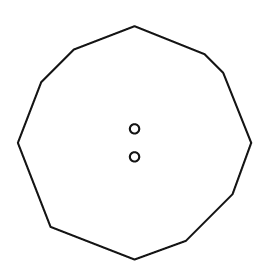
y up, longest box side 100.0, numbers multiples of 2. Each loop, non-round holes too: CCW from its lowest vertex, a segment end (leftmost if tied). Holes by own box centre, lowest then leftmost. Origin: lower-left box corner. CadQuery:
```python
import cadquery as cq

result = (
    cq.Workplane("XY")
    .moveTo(50.0, 0.0)
    .lineTo(72.0, 8.0)
    .lineTo(92.0, 28.0)
    .lineTo(100.0, 50.0)
    .lineTo(88.0, 80.0)
    .lineTo(80.0, 88.0)
    .lineTo(50.0, 100.0)
    .lineTo(24.0, 90.0)
    .lineTo(10.0, 76.0)
    .lineTo(0.0, 50.0)
    .lineTo(14.0, 14.0)
    .close()
    .moveTo(50.0, 44.0)
    .circle(2.0)
    .moveTo(50.0, 56.0)
    .circle(2.0)
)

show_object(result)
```